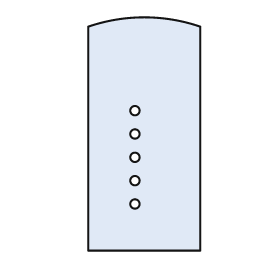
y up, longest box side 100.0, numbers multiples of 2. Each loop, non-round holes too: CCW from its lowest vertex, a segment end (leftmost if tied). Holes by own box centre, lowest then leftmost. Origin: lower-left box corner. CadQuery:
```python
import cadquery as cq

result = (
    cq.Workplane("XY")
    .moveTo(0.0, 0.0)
    .lineTo(48.0, 0.0)
    .lineTo(48.0, 96.0)
    .threePointArc((24.0, 100.0), (0.0, 96.0))
    .close()
    .moveTo(20.0, 20.0)
    .circle(2.0)
    .moveTo(20.0, 30.0)
    .circle(2.0)
    .moveTo(20.0, 40.0)
    .circle(2.0)
    .moveTo(20.0, 50.0)
    .circle(2.0)
    .moveTo(20.0, 60.0)
    .circle(2.0)
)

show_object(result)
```